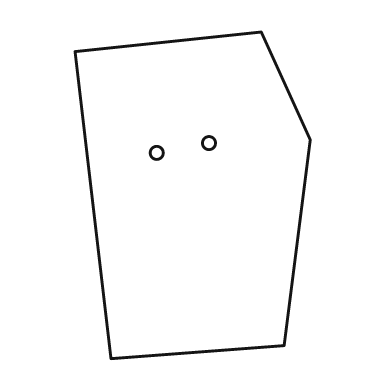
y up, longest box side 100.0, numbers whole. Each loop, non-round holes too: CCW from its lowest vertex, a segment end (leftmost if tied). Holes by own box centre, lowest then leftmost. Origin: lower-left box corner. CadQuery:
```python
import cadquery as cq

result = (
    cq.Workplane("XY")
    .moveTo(11.0, 0.0)
    .lineTo(64.0, 4.0)
    .lineTo(72.0, 67.0)
    .lineTo(57.0, 100.0)
    .lineTo(0.0, 94.0)
    .close()
    .moveTo(25.0, 63.0)
    .circle(2.0)
    .moveTo(41.0, 66.0)
    .circle(2.0)
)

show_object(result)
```